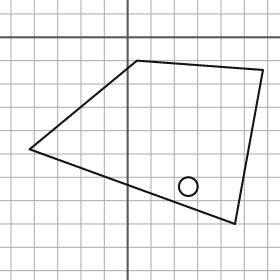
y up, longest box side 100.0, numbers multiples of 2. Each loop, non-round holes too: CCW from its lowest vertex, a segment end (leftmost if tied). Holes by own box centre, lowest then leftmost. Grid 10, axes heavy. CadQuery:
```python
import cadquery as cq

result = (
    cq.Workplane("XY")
    .moveTo(46.0, -80.0)
    .lineTo(58.0, -14.0)
    .lineTo(4.0, -10.0)
    .lineTo(-42.0, -48.0)
    .close()
    .moveTo(26.0, -64.0)
    .circle(4.0)
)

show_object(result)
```